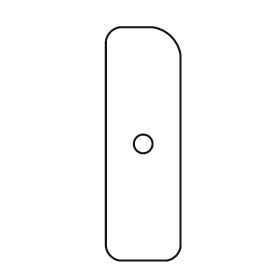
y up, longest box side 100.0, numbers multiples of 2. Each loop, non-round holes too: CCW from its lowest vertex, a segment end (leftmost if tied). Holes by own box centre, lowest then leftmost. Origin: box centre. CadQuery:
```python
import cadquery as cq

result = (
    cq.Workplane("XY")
    .moveTo(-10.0, -50.0)
    .lineTo(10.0, -50.0)
    .threePointArc((14.0, -48.0), (16.0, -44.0))
    .lineTo(16.0, 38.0)
    .threePointArc((12.0, 46.0), (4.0, 50.0))
    .lineTo(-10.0, 50.0)
    .threePointArc((-14.0, 48.0), (-16.0, 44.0))
    .lineTo(-16.0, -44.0)
    .threePointArc((-14.0, -48.0), (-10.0, -50.0))
    .close()
    .moveTo(0.0, 0.0)
    .circle(4.0)
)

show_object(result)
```